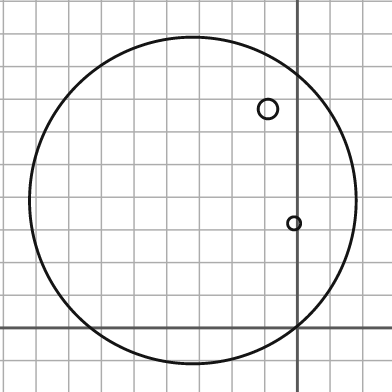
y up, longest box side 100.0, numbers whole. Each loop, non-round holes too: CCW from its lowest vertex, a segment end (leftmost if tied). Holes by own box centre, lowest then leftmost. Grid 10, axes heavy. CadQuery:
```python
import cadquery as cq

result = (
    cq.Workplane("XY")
    .moveTo(-32.0, 39.0)
    .circle(50.0)
    .moveTo(-1.0, 32.0)
    .circle(2.0)
    .moveTo(-9.0, 67.0)
    .circle(3.0)
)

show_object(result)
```